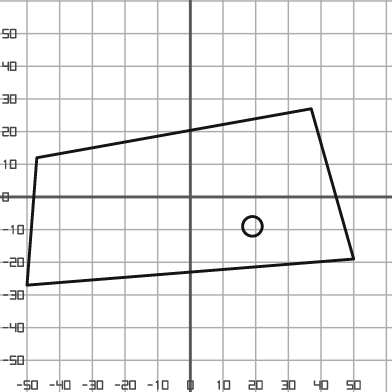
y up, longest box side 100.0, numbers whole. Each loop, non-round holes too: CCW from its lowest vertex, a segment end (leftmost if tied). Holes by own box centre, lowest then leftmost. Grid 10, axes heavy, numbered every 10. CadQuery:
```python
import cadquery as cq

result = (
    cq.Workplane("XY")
    .moveTo(-50.0, -27.0)
    .lineTo(50.0, -19.0)
    .lineTo(37.0, 27.0)
    .lineTo(-47.0, 12.0)
    .close()
    .moveTo(19.0, -9.0)
    .circle(3.0)
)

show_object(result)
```